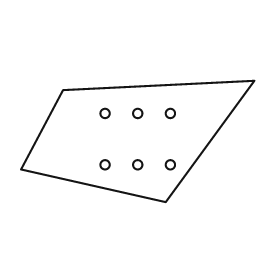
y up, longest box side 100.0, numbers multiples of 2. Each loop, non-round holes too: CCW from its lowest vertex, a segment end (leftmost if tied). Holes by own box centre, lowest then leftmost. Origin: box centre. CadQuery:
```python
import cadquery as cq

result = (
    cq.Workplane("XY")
    .moveTo(12.0, -26.0)
    .lineTo(50.0, 26.0)
    .lineTo(-32.0, 22.0)
    .lineTo(-50.0, -12.0)
    .close()
    .moveTo(-14.0, -10.0)
    .circle(2.0)
    .moveTo(0.0, -10.0)
    .circle(2.0)
    .moveTo(14.0, -10.0)
    .circle(2.0)
    .moveTo(-14.0, 12.0)
    .circle(2.0)
    .moveTo(0.0, 12.0)
    .circle(2.0)
    .moveTo(14.0, 12.0)
    .circle(2.0)
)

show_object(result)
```